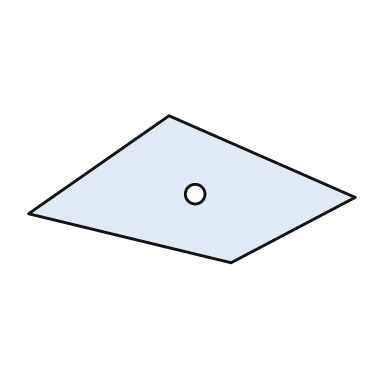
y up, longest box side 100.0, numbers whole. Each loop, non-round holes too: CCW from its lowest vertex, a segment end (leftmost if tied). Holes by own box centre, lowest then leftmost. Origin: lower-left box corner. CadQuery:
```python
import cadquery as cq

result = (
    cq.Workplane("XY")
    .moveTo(62.0, 0.0)
    .lineTo(100.0, 20.0)
    .lineTo(43.0, 45.0)
    .lineTo(0.0, 15.0)
    .close()
    .moveTo(51.0, 21.0)
    .circle(3.0)
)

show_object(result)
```